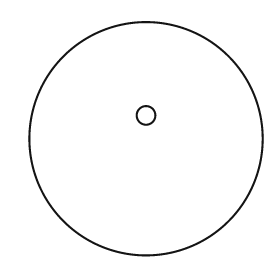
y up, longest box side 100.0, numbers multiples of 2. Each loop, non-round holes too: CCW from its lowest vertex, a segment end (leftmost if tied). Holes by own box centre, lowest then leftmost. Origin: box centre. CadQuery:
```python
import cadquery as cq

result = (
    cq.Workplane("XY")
    .moveTo(0.0, 0.0)
    .circle(50.0)
    .moveTo(0.0, 10.0)
    .circle(4.0)
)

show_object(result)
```